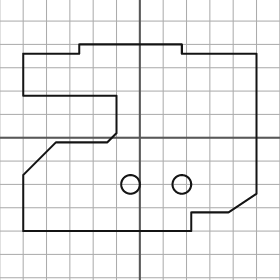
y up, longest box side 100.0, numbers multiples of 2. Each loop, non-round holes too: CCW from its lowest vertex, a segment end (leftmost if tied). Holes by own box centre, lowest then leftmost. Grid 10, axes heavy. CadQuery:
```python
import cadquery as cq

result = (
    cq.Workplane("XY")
    .moveTo(-50.0, -40.0)
    .lineTo(22.0, -40.0)
    .lineTo(22.0, -32.0)
    .lineTo(38.0, -32.0)
    .lineTo(50.0, -24.0)
    .lineTo(50.0, 36.0)
    .lineTo(18.0, 36.0)
    .lineTo(18.0, 40.0)
    .lineTo(-26.0, 40.0)
    .lineTo(-26.0, 36.0)
    .lineTo(-50.0, 36.0)
    .lineTo(-50.0, 18.0)
    .lineTo(-10.0, 18.0)
    .lineTo(-10.0, 2.0)
    .lineTo(-14.0, -2.0)
    .lineTo(-36.0, -2.0)
    .lineTo(-50.0, -16.0)
    .close()
    .moveTo(-4.0, -20.0)
    .circle(4.0)
    .moveTo(18.0, -20.0)
    .circle(4.0)
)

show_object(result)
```